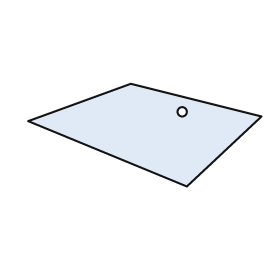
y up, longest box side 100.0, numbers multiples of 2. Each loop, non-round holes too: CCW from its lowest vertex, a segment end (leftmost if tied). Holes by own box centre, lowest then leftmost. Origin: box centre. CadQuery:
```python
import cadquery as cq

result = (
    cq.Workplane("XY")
    .moveTo(18.0, -22.0)
    .lineTo(50.0, 8.0)
    .lineTo(-6.0, 22.0)
    .lineTo(-50.0, 6.0)
    .close()
    .moveTo(16.0, 10.0)
    .circle(2.0)
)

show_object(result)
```